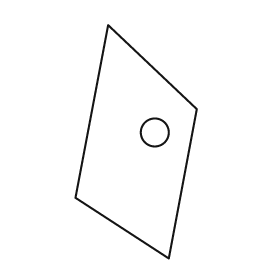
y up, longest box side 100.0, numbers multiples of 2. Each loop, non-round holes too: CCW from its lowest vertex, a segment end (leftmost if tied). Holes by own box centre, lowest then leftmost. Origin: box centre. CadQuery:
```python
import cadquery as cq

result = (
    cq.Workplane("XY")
    .moveTo(14.0, -50.0)
    .lineTo(26.0, 14.0)
    .lineTo(-12.0, 50.0)
    .lineTo(-26.0, -24.0)
    .close()
    .moveTo(8.0, 4.0)
    .circle(6.0)
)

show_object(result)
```